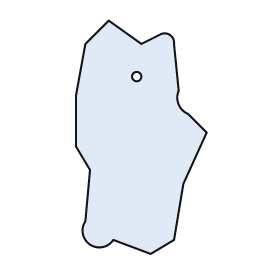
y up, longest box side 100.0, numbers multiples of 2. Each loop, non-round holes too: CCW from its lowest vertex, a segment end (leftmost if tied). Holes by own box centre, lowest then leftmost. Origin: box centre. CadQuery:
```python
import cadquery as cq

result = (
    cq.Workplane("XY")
    .moveTo(4.0, -50.0)
    .lineTo(14.0, -44.0)
    .lineTo(18.0, -20.0)
    .lineTo(28.0, 2.0)
    .lineTo(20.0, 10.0)
    .threePointArc((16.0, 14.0), (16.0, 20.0))
    .lineTo(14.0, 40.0)
    .threePointArc((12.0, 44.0), (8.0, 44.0))
    .lineTo(0.0, 40.0)
    .lineTo(-14.0, 50.0)
    .lineTo(-24.0, 40.0)
    .lineTo(-28.0, 18.0)
    .lineTo(-28.0, -4.0)
    .lineTo(-22.0, -14.0)
    .lineTo(-24.0, -36.0)
    .threePointArc((-22.0, -46.0), (-12.0, -44.0))
    .close()
    .moveTo(-2.0, 26.0)
    .circle(2.0)
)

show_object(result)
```